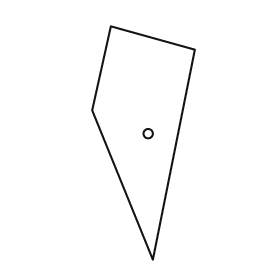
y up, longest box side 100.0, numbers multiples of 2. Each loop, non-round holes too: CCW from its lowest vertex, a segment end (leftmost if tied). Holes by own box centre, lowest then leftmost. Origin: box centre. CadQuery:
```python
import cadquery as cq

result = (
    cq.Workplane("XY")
    .moveTo(4.0, -50.0)
    .lineTo(22.0, 40.0)
    .lineTo(-14.0, 50.0)
    .lineTo(-22.0, 14.0)
    .close()
    .moveTo(2.0, 4.0)
    .circle(2.0)
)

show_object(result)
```